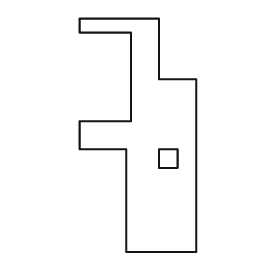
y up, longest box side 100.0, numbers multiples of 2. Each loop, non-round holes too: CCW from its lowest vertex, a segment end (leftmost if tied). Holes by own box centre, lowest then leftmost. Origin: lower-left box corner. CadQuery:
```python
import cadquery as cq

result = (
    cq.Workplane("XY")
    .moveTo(20.0, 0.0)
    .lineTo(50.0, 0.0)
    .lineTo(50.0, 74.0)
    .lineTo(34.0, 74.0)
    .lineTo(34.0, 100.0)
    .lineTo(0.0, 100.0)
    .lineTo(0.0, 94.0)
    .lineTo(22.0, 94.0)
    .lineTo(22.0, 56.0)
    .lineTo(0.0, 56.0)
    .lineTo(0.0, 44.0)
    .lineTo(20.0, 44.0)
    .close()
    .moveTo(34.0, 36.0)
    .lineTo(42.0, 36.0)
    .lineTo(42.0, 44.0)
    .lineTo(34.0, 44.0)
    .close()
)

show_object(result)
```